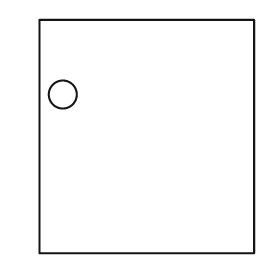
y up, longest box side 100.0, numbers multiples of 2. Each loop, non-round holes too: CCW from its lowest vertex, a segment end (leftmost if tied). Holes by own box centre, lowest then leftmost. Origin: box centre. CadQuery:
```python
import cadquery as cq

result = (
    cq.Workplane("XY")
    .moveTo(-46.0, -50.0)
    .lineTo(46.0, -50.0)
    .lineTo(46.0, 50.0)
    .lineTo(-46.0, 50.0)
    .close()
    .moveTo(-36.0, 18.0)
    .circle(6.0)
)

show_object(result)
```